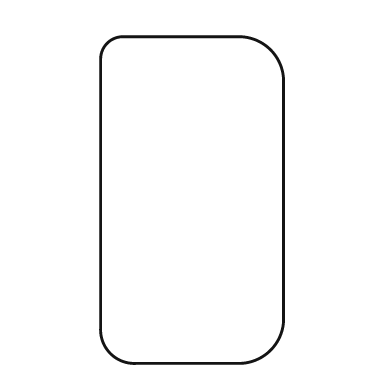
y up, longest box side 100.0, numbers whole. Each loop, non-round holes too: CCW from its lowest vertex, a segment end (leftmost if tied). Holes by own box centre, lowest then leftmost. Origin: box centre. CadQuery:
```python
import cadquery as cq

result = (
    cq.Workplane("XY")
    .moveTo(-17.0, -50.0)
    .lineTo(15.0, -50.0)
    .threePointArc((24.0, -46.0), (28.0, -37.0))
    .lineTo(28.0, 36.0)
    .threePointArc((24.0, 46.0), (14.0, 50.0))
    .lineTo(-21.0, 50.0)
    .threePointArc((-26.0, 48.0), (-28.0, 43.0))
    .lineTo(-28.0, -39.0)
    .threePointArc((-25.0, -47.0), (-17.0, -50.0))
    .close()
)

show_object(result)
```